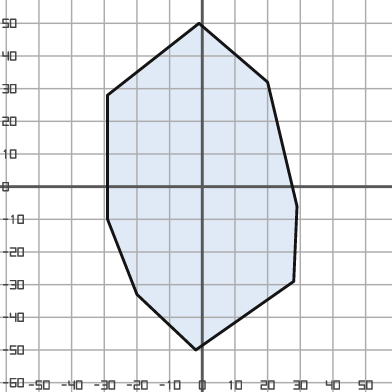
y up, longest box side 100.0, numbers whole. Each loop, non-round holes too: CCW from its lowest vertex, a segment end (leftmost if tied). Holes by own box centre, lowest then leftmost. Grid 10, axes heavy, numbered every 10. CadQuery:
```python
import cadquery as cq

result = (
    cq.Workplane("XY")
    .moveTo(-2.0, -50.0)
    .lineTo(28.0, -29.0)
    .lineTo(29.0, -6.0)
    .lineTo(20.0, 32.0)
    .lineTo(-1.0, 50.0)
    .lineTo(-29.0, 28.0)
    .lineTo(-29.0, -10.0)
    .lineTo(-20.0, -33.0)
    .close()
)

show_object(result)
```